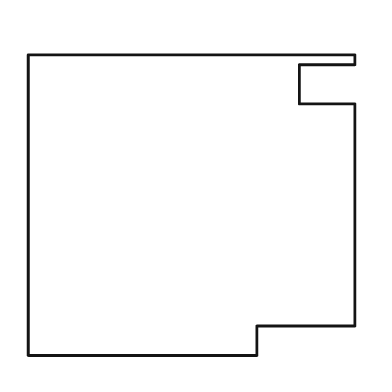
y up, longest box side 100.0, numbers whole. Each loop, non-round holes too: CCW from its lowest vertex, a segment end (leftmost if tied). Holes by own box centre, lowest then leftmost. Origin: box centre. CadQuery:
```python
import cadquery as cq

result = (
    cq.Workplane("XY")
    .moveTo(-50.0, -46.0)
    .lineTo(20.0, -46.0)
    .lineTo(20.0, -37.0)
    .lineTo(50.0, -37.0)
    .lineTo(50.0, 31.0)
    .lineTo(33.0, 31.0)
    .lineTo(33.0, 43.0)
    .lineTo(50.0, 43.0)
    .lineTo(50.0, 46.0)
    .lineTo(-50.0, 46.0)
    .close()
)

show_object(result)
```